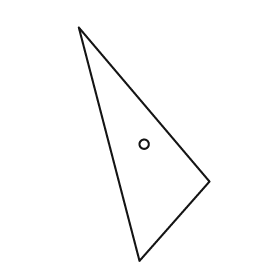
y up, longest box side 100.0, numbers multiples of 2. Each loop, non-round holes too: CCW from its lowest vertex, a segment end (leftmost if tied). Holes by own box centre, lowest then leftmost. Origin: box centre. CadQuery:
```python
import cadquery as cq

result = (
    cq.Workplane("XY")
    .moveTo(-2.0, -50.0)
    .lineTo(28.0, -16.0)
    .lineTo(-28.0, 50.0)
    .close()
    .moveTo(0.0, 0.0)
    .circle(2.0)
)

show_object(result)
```